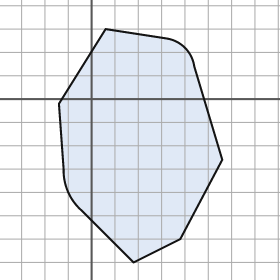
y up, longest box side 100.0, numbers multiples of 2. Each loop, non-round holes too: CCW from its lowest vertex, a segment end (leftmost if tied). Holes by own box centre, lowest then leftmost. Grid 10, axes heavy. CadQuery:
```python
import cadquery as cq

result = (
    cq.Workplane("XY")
    .moveTo(18.0, -70.0)
    .lineTo(38.0, -60.0)
    .lineTo(56.0, -26.0)
    .lineTo(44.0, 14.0)
    .threePointArc((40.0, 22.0), (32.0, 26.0))
    .lineTo(6.0, 30.0)
    .lineTo(-14.0, -2.0)
    .lineTo(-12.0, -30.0)
    .threePointArc((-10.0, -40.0), (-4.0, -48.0))
    .close()
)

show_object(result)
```